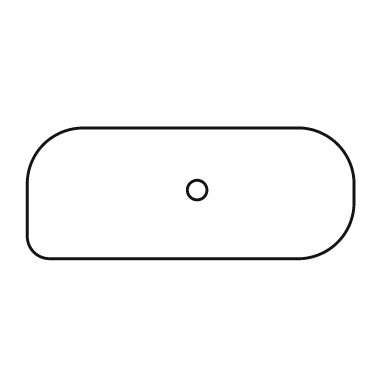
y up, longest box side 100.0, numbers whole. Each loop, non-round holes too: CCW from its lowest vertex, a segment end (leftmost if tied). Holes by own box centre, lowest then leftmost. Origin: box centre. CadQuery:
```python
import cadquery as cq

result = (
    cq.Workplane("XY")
    .moveTo(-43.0, -20.0)
    .lineTo(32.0, -20.0)
    .threePointArc((45.0, -15.0), (50.0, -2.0))
    .lineTo(50.0, 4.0)
    .threePointArc((45.0, 15.0), (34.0, 20.0))
    .lineTo(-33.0, 20.0)
    .threePointArc((-45.0, 15.0), (-50.0, 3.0))
    .lineTo(-50.0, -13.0)
    .threePointArc((-48.0, -18.0), (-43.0, -20.0))
    .close()
    .moveTo(2.0, 1.0)
    .circle(3.0)
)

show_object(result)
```